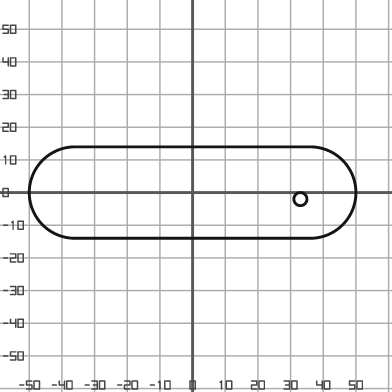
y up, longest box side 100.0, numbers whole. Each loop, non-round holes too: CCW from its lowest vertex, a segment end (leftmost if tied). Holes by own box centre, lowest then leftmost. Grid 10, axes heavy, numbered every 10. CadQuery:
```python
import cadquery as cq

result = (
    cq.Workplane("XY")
    .moveTo(-36.0, -14.0)
    .lineTo(36.0, -14.0)
    .threePointArc((50.0, 0.0), (36.0, 14.0))
    .lineTo(-36.0, 14.0)
    .threePointArc((-50.0, 0.0), (-36.0, -14.0))
    .close()
    .moveTo(33.0, -2.0)
    .circle(2.0)
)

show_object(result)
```